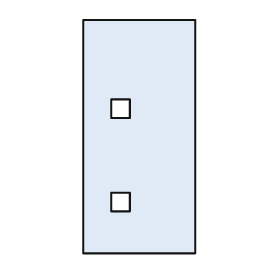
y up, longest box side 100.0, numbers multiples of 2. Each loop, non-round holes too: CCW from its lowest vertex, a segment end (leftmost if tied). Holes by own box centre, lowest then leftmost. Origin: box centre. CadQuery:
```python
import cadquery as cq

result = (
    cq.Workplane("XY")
    .moveTo(-24.0, -50.0)
    .lineTo(24.0, -50.0)
    .lineTo(24.0, 50.0)
    .lineTo(-24.0, 50.0)
    .close()
    .moveTo(-12.0, -32.0)
    .lineTo(-4.0, -32.0)
    .lineTo(-4.0, -24.0)
    .lineTo(-12.0, -24.0)
    .close()
    .moveTo(-12.0, 8.0)
    .lineTo(-4.0, 8.0)
    .lineTo(-4.0, 16.0)
    .lineTo(-12.0, 16.0)
    .close()
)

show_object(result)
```